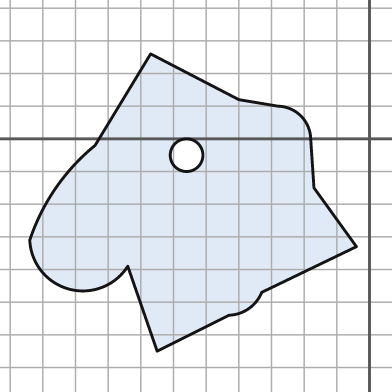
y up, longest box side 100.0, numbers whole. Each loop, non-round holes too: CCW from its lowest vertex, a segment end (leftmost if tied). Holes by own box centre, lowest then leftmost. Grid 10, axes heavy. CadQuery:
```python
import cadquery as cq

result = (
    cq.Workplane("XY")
    .moveTo(-65.0, -65.0)
    .lineTo(-43.0, -54.0)
    .threePointArc((-37.0, -52.0), (-33.0, -47.0))
    .lineTo(-4.0, -33.0)
    .lineTo(-17.0, -15.0)
    .lineTo(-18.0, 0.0)
    .threePointArc((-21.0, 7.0), (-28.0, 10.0))
    .lineTo(-40.0, 12.0)
    .lineTo(-67.0, 26.0)
    .lineTo(-84.0, -2.0)
    .threePointArc((-96.0, -15.0), (-104.0, -31.0))
    .threePointArc((-92.0, -46.0), (-74.0, -39.0))
    .close()
    .moveTo(-56.0, -5.0)
    .circle(5.0)
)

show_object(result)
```